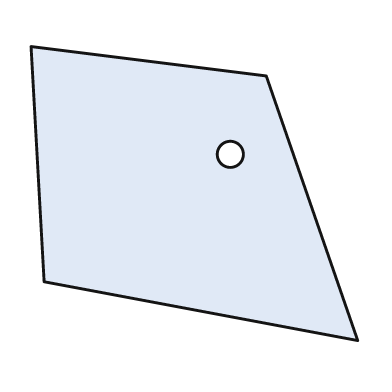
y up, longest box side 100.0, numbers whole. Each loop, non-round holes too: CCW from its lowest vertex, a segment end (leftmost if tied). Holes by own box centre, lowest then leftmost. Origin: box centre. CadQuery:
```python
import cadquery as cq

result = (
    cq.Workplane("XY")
    .moveTo(50.0, -45.0)
    .lineTo(22.0, 36.0)
    .lineTo(-50.0, 45.0)
    .lineTo(-46.0, -27.0)
    .close()
    .moveTo(11.0, 12.0)
    .circle(4.0)
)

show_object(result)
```